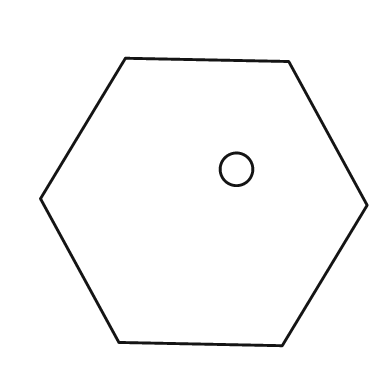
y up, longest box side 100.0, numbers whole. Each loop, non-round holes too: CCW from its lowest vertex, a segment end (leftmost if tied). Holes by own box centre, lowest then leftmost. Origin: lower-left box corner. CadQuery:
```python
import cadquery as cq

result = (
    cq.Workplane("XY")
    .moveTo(74.0, 0.0)
    .lineTo(100.0, 43.0)
    .lineTo(76.0, 87.0)
    .lineTo(26.0, 88.0)
    .lineTo(0.0, 45.0)
    .lineTo(24.0, 1.0)
    .close()
    .moveTo(60.0, 54.0)
    .circle(5.0)
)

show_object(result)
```